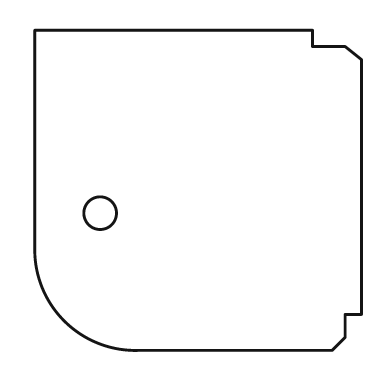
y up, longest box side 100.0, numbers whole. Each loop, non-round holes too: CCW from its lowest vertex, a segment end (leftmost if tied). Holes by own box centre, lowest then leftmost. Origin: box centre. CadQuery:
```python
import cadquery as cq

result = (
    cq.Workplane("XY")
    .moveTo(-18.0, -49.0)
    .lineTo(41.0, -49.0)
    .lineTo(45.0, -45.0)
    .lineTo(45.0, -38.0)
    .lineTo(50.0, -38.0)
    .lineTo(50.0, 40.0)
    .lineTo(45.0, 44.0)
    .lineTo(35.0, 44.0)
    .lineTo(35.0, 49.0)
    .lineTo(-50.0, 49.0)
    .lineTo(-50.0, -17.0)
    .threePointArc((-41.0, -40.0), (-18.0, -49.0))
    .close()
    .moveTo(-30.0, -7.0)
    .circle(5.0)
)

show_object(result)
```